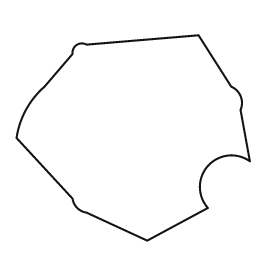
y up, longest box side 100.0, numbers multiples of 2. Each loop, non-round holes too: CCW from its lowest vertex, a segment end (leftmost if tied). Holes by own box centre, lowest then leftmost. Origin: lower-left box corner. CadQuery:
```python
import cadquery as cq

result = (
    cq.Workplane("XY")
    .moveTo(56.0, 0.0)
    .lineTo(82.0, 14.0)
    .threePointArc((82.0, 32.0), (100.0, 34.0))
    .lineTo(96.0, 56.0)
    .threePointArc((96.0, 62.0), (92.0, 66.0))
    .lineTo(78.0, 88.0)
    .lineTo(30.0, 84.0)
    .threePointArc((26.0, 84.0), (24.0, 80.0))
    .lineTo(12.0, 66.0)
    .threePointArc((4.0, 56.0), (0.0, 44.0))
    .lineTo(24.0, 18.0)
    .threePointArc((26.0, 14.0), (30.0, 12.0))
    .close()
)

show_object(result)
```